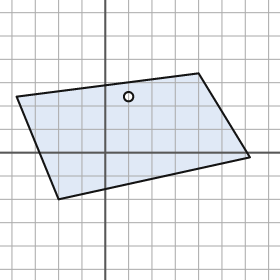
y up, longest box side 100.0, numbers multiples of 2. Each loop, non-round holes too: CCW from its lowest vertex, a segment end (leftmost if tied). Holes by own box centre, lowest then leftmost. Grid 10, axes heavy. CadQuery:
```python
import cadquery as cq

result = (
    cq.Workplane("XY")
    .moveTo(-20.0, -20.0)
    .lineTo(62.0, -2.0)
    .lineTo(40.0, 34.0)
    .lineTo(-38.0, 24.0)
    .close()
    .moveTo(10.0, 24.0)
    .circle(2.0)
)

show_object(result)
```